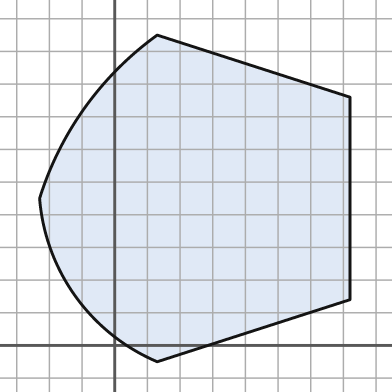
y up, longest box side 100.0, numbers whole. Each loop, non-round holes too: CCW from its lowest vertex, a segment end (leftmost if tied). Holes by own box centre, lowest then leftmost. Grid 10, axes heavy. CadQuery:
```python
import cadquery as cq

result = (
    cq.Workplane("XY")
    .moveTo(13.0, -5.0)
    .lineTo(72.0, 14.0)
    .lineTo(72.0, 76.0)
    .lineTo(13.0, 95.0)
    .threePointArc((-9.0, 73.0), (-23.0, 45.0))
    .threePointArc((-12.0, 15.0), (13.0, -5.0))
    .close()
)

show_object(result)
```